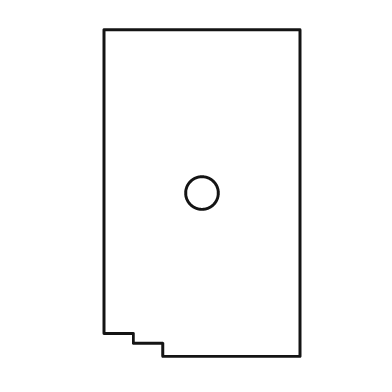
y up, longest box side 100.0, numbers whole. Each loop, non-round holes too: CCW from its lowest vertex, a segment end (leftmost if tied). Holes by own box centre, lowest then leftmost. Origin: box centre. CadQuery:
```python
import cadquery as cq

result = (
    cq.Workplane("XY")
    .moveTo(-12.0, -50.0)
    .lineTo(30.0, -50.0)
    .lineTo(30.0, 50.0)
    .lineTo(-30.0, 50.0)
    .lineTo(-30.0, -43.0)
    .lineTo(-21.0, -43.0)
    .lineTo(-21.0, -46.0)
    .lineTo(-12.0, -46.0)
    .close()
    .moveTo(0.0, 0.0)
    .circle(5.0)
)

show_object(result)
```